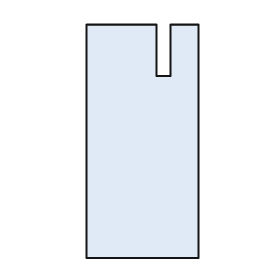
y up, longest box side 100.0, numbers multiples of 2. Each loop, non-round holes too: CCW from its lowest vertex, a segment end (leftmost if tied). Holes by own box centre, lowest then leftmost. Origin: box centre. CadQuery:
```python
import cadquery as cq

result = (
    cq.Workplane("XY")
    .moveTo(-24.0, -50.0)
    .lineTo(24.0, -50.0)
    .lineTo(24.0, 50.0)
    .lineTo(12.0, 50.0)
    .lineTo(12.0, 28.0)
    .lineTo(6.0, 28.0)
    .lineTo(6.0, 50.0)
    .lineTo(-24.0, 50.0)
    .close()
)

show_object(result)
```